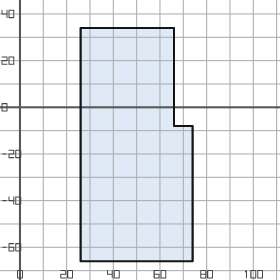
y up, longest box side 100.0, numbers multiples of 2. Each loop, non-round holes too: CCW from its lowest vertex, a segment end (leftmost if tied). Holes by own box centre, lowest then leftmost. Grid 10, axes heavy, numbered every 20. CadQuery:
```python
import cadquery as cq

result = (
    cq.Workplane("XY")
    .moveTo(26.0, -66.0)
    .lineTo(74.0, -66.0)
    .lineTo(74.0, -8.0)
    .lineTo(66.0, -8.0)
    .lineTo(66.0, 34.0)
    .lineTo(26.0, 34.0)
    .close()
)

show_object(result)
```